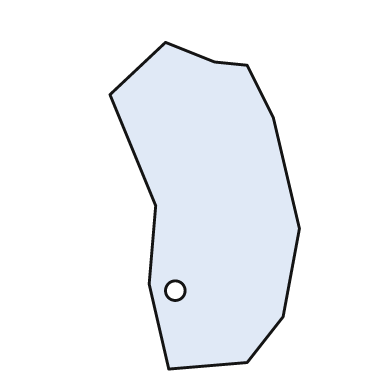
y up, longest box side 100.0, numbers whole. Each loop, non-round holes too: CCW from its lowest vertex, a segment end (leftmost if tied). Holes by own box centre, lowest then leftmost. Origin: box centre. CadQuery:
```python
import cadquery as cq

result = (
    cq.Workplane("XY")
    .moveTo(-11.0, -50.0)
    .lineTo(13.0, -48.0)
    .lineTo(24.0, -34.0)
    .lineTo(29.0, -7.0)
    .lineTo(21.0, 27.0)
    .lineTo(13.0, 43.0)
    .lineTo(3.0, 44.0)
    .lineTo(-12.0, 50.0)
    .lineTo(-29.0, 34.0)
    .lineTo(-15.0, 0.0)
    .lineTo(-17.0, -24.0)
    .close()
    .moveTo(-9.0, -26.0)
    .circle(3.0)
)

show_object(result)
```